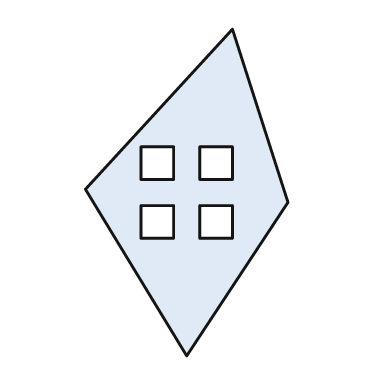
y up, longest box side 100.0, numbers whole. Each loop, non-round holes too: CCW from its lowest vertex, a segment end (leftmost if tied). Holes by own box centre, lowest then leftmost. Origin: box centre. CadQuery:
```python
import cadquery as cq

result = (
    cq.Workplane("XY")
    .moveTo(0.0, -50.0)
    .lineTo(31.0, -3.0)
    .lineTo(14.0, 50.0)
    .lineTo(-31.0, 1.0)
    .close()
    .moveTo(-14.0, -14.0)
    .lineTo(-4.0, -14.0)
    .lineTo(-4.0, -4.0)
    .lineTo(-14.0, -4.0)
    .close()
    .moveTo(4.0, -14.0)
    .lineTo(14.0, -14.0)
    .lineTo(14.0, -4.0)
    .lineTo(4.0, -4.0)
    .close()
    .moveTo(-14.0, 4.0)
    .lineTo(-4.0, 4.0)
    .lineTo(-4.0, 14.0)
    .lineTo(-14.0, 14.0)
    .close()
    .moveTo(4.0, 4.0)
    .lineTo(14.0, 4.0)
    .lineTo(14.0, 14.0)
    .lineTo(4.0, 14.0)
    .close()
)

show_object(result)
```